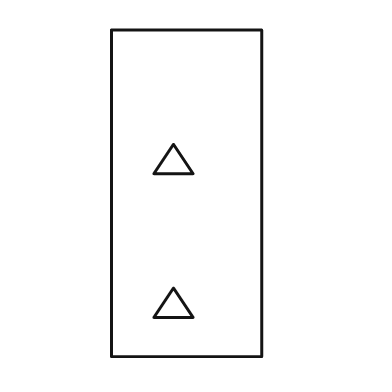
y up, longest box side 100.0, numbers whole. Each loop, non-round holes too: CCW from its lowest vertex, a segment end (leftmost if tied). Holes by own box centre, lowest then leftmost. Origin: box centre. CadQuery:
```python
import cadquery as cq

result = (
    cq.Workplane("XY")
    .moveTo(-23.0, -50.0)
    .lineTo(23.0, -50.0)
    .lineTo(23.0, 50.0)
    .lineTo(-23.0, 50.0)
    .close()
    .moveTo(-10.0, -38.0)
    .lineTo(2.0, -38.0)
    .lineTo(-4.0, -29.0)
    .close()
    .moveTo(-10.0, 6.0)
    .lineTo(2.0, 6.0)
    .lineTo(-4.0, 15.0)
    .close()
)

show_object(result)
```